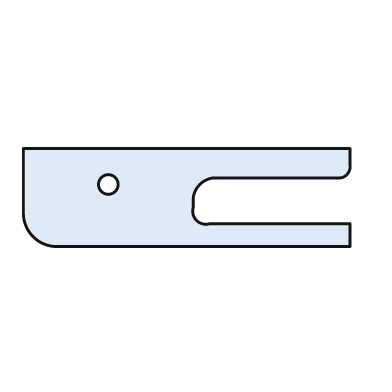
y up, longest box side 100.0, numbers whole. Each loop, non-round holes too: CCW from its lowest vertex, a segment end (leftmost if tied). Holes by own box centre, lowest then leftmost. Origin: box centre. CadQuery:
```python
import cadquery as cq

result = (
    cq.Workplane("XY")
    .moveTo(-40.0, -15.0)
    .lineTo(50.0, -15.0)
    .lineTo(50.0, -8.0)
    .lineTo(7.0, -8.0)
    .threePointArc((3.0, -7.0), (2.0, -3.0))
    .lineTo(2.0, 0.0)
    .threePointArc((4.0, 4.0), (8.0, 6.0))
    .lineTo(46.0, 6.0)
    .threePointArc((49.0, 7.0), (50.0, 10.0))
    .lineTo(50.0, 15.0)
    .lineTo(-50.0, 15.0)
    .lineTo(-50.0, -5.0)
    .threePointArc((-47.0, -12.0), (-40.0, -15.0))
    .close()
    .moveTo(-24.0, 4.0)
    .circle(3.0)
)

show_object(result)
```